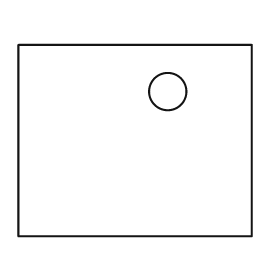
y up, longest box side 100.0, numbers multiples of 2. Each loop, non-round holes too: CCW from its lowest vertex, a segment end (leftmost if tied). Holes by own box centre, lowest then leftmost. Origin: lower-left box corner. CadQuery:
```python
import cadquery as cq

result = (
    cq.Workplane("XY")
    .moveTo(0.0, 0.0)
    .lineTo(100.0, 0.0)
    .lineTo(100.0, 82.0)
    .lineTo(0.0, 82.0)
    .close()
    .moveTo(64.0, 62.0)
    .circle(8.0)
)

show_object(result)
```